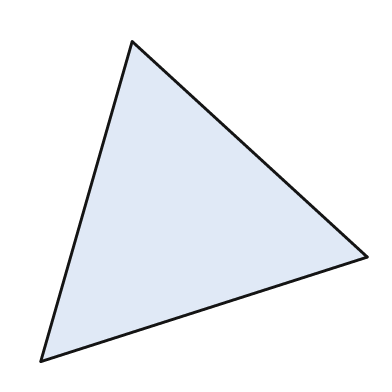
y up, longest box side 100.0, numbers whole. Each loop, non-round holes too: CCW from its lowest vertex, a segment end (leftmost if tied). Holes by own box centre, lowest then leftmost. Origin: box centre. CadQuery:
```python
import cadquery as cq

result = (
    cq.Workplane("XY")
    .moveTo(-50.0, -49.0)
    .lineTo(50.0, -17.0)
    .lineTo(-22.0, 49.0)
    .close()
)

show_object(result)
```